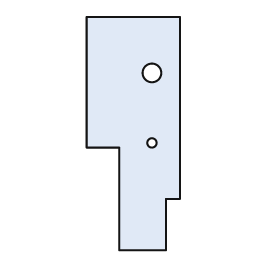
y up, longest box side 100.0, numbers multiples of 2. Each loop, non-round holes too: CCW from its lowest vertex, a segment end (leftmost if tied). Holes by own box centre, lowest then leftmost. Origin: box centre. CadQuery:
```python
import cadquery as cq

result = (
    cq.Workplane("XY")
    .moveTo(-6.0, -50.0)
    .lineTo(14.0, -50.0)
    .lineTo(14.0, -28.0)
    .lineTo(20.0, -28.0)
    .lineTo(20.0, 50.0)
    .lineTo(-20.0, 50.0)
    .lineTo(-20.0, -6.0)
    .lineTo(-6.0, -6.0)
    .close()
    .moveTo(8.0, -4.0)
    .circle(2.0)
    .moveTo(8.0, 26.0)
    .circle(4.0)
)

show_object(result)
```